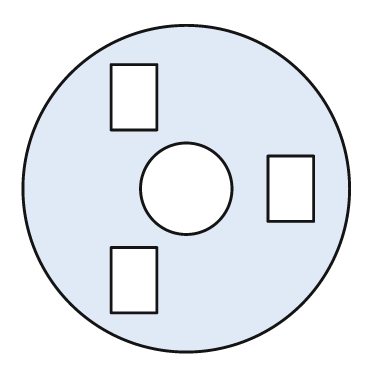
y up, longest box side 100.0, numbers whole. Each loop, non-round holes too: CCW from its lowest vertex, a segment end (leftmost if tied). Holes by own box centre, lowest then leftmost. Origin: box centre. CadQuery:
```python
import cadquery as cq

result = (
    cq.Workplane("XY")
    .moveTo(0.0, 0.0)
    .circle(50.0)
    .moveTo(-23.0, -38.0)
    .lineTo(-9.0, -38.0)
    .lineTo(-9.0, -18.0)
    .lineTo(-23.0, -18.0)
    .close()
    .moveTo(0.0, 0.0)
    .circle(14.0)
    .moveTo(25.0, -10.0)
    .lineTo(39.0, -10.0)
    .lineTo(39.0, 10.0)
    .lineTo(25.0, 10.0)
    .close()
    .moveTo(-23.0, 18.0)
    .lineTo(-9.0, 18.0)
    .lineTo(-9.0, 38.0)
    .lineTo(-23.0, 38.0)
    .close()
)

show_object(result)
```